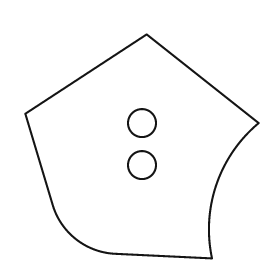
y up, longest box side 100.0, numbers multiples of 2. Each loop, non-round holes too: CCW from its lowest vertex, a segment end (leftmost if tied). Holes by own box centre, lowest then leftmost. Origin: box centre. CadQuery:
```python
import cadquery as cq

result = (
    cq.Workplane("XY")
    .moveTo(30.0, -48.0)
    .threePointArc((32.0, -16.0), (50.0, 10.0))
    .lineTo(2.0, 48.0)
    .lineTo(-50.0, 14.0)
    .lineTo(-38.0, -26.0)
    .threePointArc((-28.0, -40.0), (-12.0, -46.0))
    .close()
    .moveTo(0.0, -8.0)
    .circle(6.0)
    .moveTo(0.0, 10.0)
    .circle(6.0)
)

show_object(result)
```